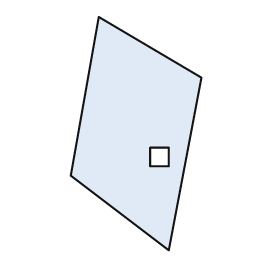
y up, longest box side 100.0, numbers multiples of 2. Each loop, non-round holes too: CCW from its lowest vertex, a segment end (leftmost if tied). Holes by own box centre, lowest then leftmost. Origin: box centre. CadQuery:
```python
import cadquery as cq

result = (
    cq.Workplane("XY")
    .moveTo(14.0, -50.0)
    .lineTo(28.0, 24.0)
    .lineTo(-16.0, 50.0)
    .lineTo(-28.0, -18.0)
    .close()
    .moveTo(6.0, -14.0)
    .lineTo(14.0, -14.0)
    .lineTo(14.0, -6.0)
    .lineTo(6.0, -6.0)
    .close()
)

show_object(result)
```